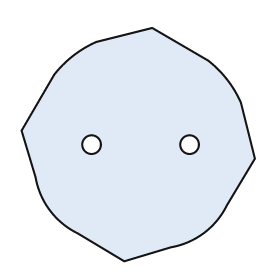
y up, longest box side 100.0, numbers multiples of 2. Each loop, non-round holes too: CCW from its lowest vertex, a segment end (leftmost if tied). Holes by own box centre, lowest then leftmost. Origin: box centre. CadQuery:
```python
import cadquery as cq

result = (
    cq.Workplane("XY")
    .moveTo(-6.0, -50.0)
    .lineTo(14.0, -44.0)
    .threePointArc((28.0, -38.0), (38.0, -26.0))
    .lineTo(50.0, -6.0)
    .lineTo(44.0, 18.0)
    .threePointArc((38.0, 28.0), (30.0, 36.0))
    .lineTo(6.0, 50.0)
    .lineTo(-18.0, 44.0)
    .threePointArc((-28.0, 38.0), (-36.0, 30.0))
    .lineTo(-50.0, 6.0)
    .lineTo(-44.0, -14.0)
    .threePointArc((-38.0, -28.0), (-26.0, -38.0))
    .close()
    .moveTo(-20.0, 0.0)
    .circle(4.0)
    .moveTo(22.0, 0.0)
    .circle(4.0)
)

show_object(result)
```